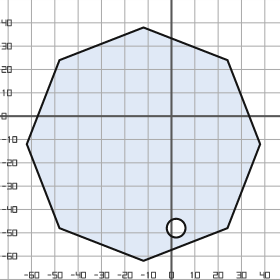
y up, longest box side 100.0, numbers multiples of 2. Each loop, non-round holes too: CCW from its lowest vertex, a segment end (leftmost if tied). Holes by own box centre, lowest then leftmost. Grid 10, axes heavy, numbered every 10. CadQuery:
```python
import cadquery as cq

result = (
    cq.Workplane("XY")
    .moveTo(-12.0, -62.0)
    .lineTo(24.0, -48.0)
    .lineTo(38.0, -12.0)
    .lineTo(24.0, 24.0)
    .lineTo(-12.0, 38.0)
    .lineTo(-48.0, 24.0)
    .lineTo(-62.0, -12.0)
    .lineTo(-48.0, -48.0)
    .close()
    .moveTo(2.0, -48.0)
    .circle(4.0)
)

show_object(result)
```